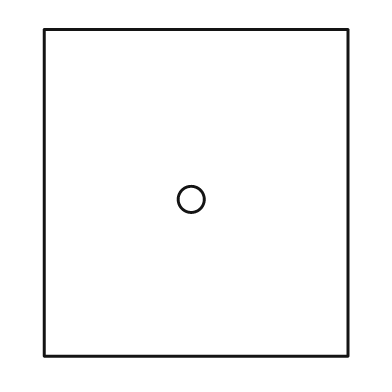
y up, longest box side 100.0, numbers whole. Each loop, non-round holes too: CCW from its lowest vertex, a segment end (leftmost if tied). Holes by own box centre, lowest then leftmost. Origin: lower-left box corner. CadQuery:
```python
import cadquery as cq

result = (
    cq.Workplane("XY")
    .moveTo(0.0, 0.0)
    .lineTo(93.0, 0.0)
    .lineTo(93.0, 100.0)
    .lineTo(0.0, 100.0)
    .close()
    .moveTo(45.0, 48.0)
    .circle(4.0)
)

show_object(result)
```